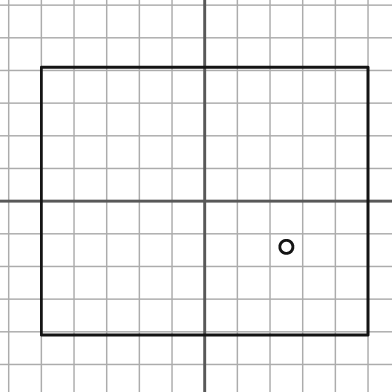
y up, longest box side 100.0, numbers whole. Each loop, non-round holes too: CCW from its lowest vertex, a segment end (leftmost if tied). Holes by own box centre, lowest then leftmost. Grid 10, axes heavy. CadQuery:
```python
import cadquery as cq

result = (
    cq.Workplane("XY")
    .moveTo(-50.0, -41.0)
    .lineTo(50.0, -41.0)
    .lineTo(50.0, 41.0)
    .lineTo(-50.0, 41.0)
    .close()
    .moveTo(25.0, -14.0)
    .circle(2.0)
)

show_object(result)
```